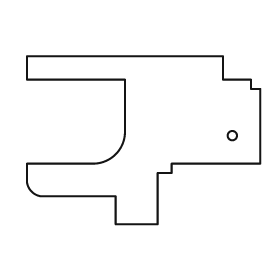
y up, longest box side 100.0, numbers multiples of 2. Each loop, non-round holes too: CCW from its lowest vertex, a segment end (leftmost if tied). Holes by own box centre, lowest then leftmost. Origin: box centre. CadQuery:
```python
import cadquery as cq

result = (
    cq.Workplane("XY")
    .moveTo(-12.0, -36.0)
    .lineTo(6.0, -36.0)
    .lineTo(6.0, -14.0)
    .lineTo(12.0, -14.0)
    .lineTo(12.0, -10.0)
    .lineTo(50.0, -10.0)
    .lineTo(50.0, 22.0)
    .lineTo(46.0, 22.0)
    .lineTo(46.0, 26.0)
    .lineTo(34.0, 26.0)
    .lineTo(34.0, 36.0)
    .lineTo(-50.0, 36.0)
    .lineTo(-50.0, 26.0)
    .lineTo(-8.0, 26.0)
    .lineTo(-8.0, 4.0)
    .threePointArc((-12.0, -6.0), (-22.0, -10.0))
    .lineTo(-50.0, -10.0)
    .lineTo(-50.0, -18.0)
    .threePointArc((-48.0, -22.0), (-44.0, -24.0))
    .lineTo(-12.0, -24.0)
    .close()
    .moveTo(38.0, 2.0)
    .circle(2.0)
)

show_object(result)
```